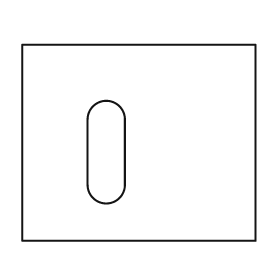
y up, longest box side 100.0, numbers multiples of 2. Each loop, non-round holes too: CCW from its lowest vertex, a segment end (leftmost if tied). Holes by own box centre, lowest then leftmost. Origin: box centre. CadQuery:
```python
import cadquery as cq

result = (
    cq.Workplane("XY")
    .moveTo(-50.0, -42.0)
    .lineTo(50.0, -42.0)
    .lineTo(50.0, 42.0)
    .lineTo(-50.0, 42.0)
    .close()
    .moveTo(-22.0, -18.0)
    .threePointArc((-14.0, -26.0), (-6.0, -18.0))
    .lineTo(-6.0, 10.0)
    .threePointArc((-14.0, 18.0), (-22.0, 10.0))
    .close()
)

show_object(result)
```